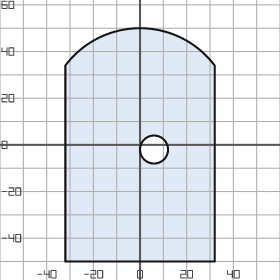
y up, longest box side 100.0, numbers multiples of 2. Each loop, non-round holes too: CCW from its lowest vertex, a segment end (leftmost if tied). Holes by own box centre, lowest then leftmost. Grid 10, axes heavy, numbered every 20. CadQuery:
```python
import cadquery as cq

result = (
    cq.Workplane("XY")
    .moveTo(-32.0, -50.0)
    .lineTo(32.0, -50.0)
    .lineTo(32.0, 34.0)
    .threePointArc((0.0, 50.0), (-32.0, 34.0))
    .close()
    .moveTo(6.0, -2.0)
    .circle(6.0)
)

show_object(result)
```